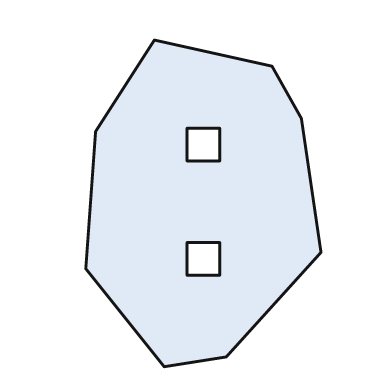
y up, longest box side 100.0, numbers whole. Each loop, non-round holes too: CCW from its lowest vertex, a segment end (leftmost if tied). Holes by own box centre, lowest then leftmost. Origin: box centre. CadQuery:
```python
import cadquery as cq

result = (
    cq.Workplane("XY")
    .moveTo(-12.0, -50.0)
    .lineTo(7.0, -47.0)
    .lineTo(36.0, -15.0)
    .lineTo(30.0, 26.0)
    .lineTo(21.0, 42.0)
    .lineTo(-15.0, 50.0)
    .lineTo(-33.0, 22.0)
    .lineTo(-36.0, -20.0)
    .close()
    .moveTo(-5.0, -22.0)
    .lineTo(5.0, -22.0)
    .lineTo(5.0, -12.0)
    .lineTo(-5.0, -12.0)
    .close()
    .moveTo(-5.0, 13.0)
    .lineTo(5.0, 13.0)
    .lineTo(5.0, 23.0)
    .lineTo(-5.0, 23.0)
    .close()
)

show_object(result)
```